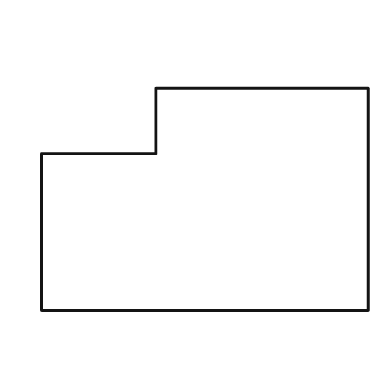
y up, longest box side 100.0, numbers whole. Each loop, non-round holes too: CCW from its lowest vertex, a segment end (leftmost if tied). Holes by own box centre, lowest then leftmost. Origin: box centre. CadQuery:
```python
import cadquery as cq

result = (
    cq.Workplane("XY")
    .moveTo(-50.0, -34.0)
    .lineTo(50.0, -34.0)
    .lineTo(50.0, 34.0)
    .lineTo(-15.0, 34.0)
    .lineTo(-15.0, 14.0)
    .lineTo(-50.0, 14.0)
    .close()
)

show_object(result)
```